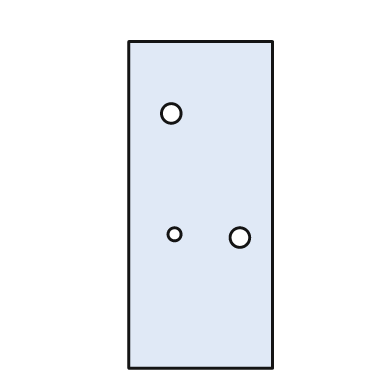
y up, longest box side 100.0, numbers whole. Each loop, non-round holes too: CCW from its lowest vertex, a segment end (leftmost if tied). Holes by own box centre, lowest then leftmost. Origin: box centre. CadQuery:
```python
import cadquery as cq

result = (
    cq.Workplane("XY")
    .moveTo(-22.0, -50.0)
    .lineTo(22.0, -50.0)
    .lineTo(22.0, 50.0)
    .lineTo(-22.0, 50.0)
    .close()
    .moveTo(12.0, -10.0)
    .circle(3.0)
    .moveTo(-8.0, -9.0)
    .circle(2.0)
    .moveTo(-9.0, 28.0)
    .circle(3.0)
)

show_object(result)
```